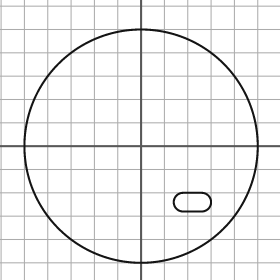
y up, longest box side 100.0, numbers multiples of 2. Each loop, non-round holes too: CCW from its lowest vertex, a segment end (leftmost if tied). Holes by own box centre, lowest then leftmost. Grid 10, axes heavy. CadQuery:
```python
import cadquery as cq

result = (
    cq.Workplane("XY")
    .moveTo(0.0, 0.0)
    .circle(50.0)
    .moveTo(18.0, -28.0)
    .lineTo(26.0, -28.0)
    .threePointArc((30.0, -24.0), (26.0, -20.0))
    .lineTo(18.0, -20.0)
    .threePointArc((14.0, -24.0), (18.0, -28.0))
    .close()
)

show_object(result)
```